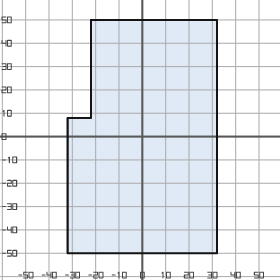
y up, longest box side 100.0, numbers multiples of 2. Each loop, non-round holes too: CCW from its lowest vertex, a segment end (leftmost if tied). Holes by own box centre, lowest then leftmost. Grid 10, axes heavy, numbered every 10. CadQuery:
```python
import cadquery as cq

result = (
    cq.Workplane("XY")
    .moveTo(-32.0, -50.0)
    .lineTo(32.0, -50.0)
    .lineTo(32.0, 50.0)
    .lineTo(-22.0, 50.0)
    .lineTo(-22.0, 8.0)
    .lineTo(-32.0, 8.0)
    .close()
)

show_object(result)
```